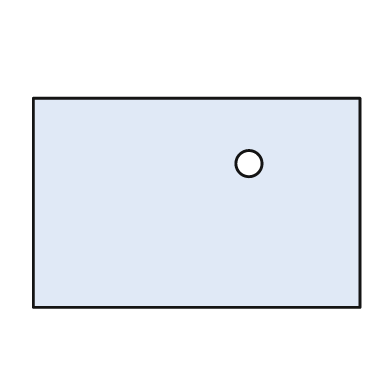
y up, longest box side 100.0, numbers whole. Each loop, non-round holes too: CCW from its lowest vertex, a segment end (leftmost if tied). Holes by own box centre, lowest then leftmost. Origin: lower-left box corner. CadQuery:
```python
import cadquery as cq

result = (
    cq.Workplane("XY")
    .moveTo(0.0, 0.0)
    .lineTo(100.0, 0.0)
    .lineTo(100.0, 64.0)
    .lineTo(0.0, 64.0)
    .close()
    .moveTo(66.0, 44.0)
    .circle(4.0)
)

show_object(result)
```